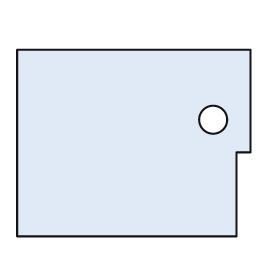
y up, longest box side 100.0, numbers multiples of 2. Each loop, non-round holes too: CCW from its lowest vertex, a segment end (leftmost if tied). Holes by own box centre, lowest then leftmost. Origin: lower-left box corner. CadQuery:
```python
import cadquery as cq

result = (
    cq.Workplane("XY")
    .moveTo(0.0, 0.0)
    .lineTo(94.0, 0.0)
    .lineTo(94.0, 36.0)
    .lineTo(100.0, 36.0)
    .lineTo(100.0, 80.0)
    .lineTo(0.0, 80.0)
    .close()
    .moveTo(84.0, 50.0)
    .circle(6.0)
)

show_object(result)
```